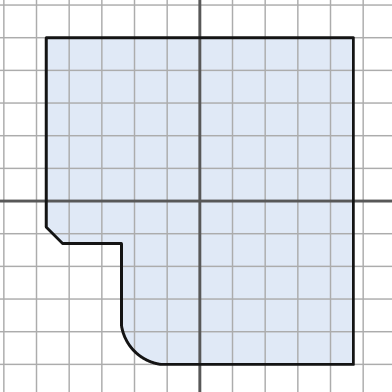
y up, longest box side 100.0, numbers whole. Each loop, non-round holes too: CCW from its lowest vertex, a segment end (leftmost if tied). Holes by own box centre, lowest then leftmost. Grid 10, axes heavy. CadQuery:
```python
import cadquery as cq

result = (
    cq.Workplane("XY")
    .moveTo(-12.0, -50.0)
    .lineTo(47.0, -50.0)
    .lineTo(47.0, 50.0)
    .lineTo(-47.0, 50.0)
    .lineTo(-47.0, -8.0)
    .lineTo(-42.0, -13.0)
    .lineTo(-24.0, -13.0)
    .lineTo(-24.0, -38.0)
    .threePointArc((-20.0, -46.0), (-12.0, -50.0))
    .close()
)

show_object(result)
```